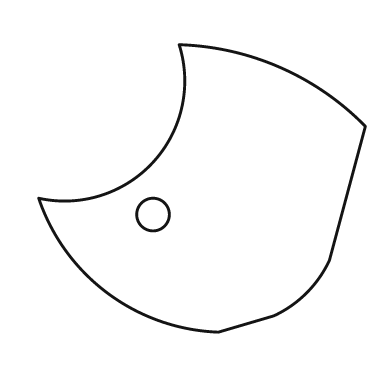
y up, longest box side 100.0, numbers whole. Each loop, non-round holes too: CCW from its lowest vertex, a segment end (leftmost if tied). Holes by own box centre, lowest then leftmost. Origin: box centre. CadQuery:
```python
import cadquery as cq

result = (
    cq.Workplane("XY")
    .moveTo(5.0, -44.0)
    .lineTo(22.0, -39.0)
    .threePointArc((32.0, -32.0), (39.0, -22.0))
    .lineTo(50.0, 19.0)
    .threePointArc((24.0, 37.0), (-7.0, 44.0))
    .threePointArc((-15.0, 8.0), (-50.0, -3.0))
    .threePointArc((-29.0, -32.0), (5.0, -44.0))
    .close()
    .moveTo(-15.0, -8.0)
    .circle(5.0)
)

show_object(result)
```